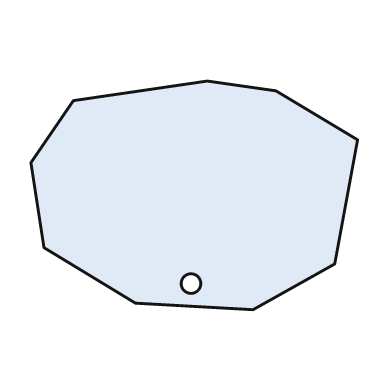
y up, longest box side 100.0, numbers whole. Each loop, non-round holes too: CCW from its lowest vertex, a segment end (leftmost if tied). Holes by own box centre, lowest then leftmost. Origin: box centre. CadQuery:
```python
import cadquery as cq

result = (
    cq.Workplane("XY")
    .moveTo(18.0, -35.0)
    .lineTo(43.0, -21.0)
    .lineTo(50.0, 17.0)
    .lineTo(25.0, 32.0)
    .lineTo(4.0, 35.0)
    .lineTo(-37.0, 29.0)
    .lineTo(-50.0, 10.0)
    .lineTo(-46.0, -16.0)
    .lineTo(-18.0, -33.0)
    .close()
    .moveTo(-1.0, -27.0)
    .circle(3.0)
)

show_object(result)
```